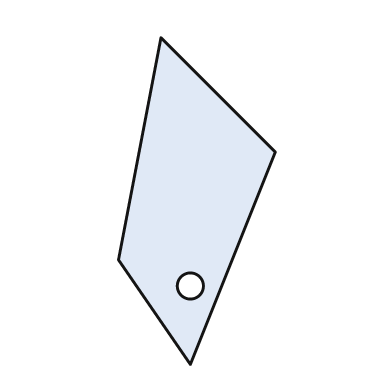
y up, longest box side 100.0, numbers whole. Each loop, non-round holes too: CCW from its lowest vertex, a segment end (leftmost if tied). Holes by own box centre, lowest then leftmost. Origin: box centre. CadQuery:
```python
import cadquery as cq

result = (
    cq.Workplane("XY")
    .moveTo(-2.0, -50.0)
    .lineTo(24.0, 15.0)
    .lineTo(-11.0, 50.0)
    .lineTo(-24.0, -18.0)
    .close()
    .moveTo(-2.0, -26.0)
    .circle(4.0)
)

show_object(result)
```